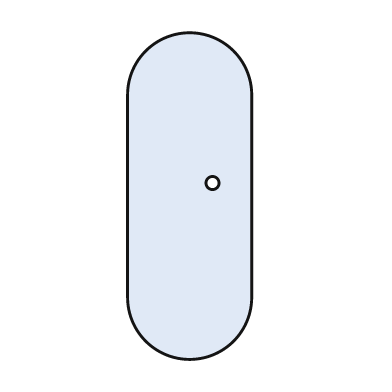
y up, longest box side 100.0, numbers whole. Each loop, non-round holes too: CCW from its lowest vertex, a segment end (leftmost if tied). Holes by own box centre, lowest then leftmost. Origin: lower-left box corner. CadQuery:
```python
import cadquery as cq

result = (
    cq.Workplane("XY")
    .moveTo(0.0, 19.0)
    .threePointArc((19.0, 0.0), (38.0, 19.0))
    .lineTo(38.0, 81.0)
    .threePointArc((19.0, 100.0), (0.0, 81.0))
    .close()
    .moveTo(26.0, 54.0)
    .circle(2.0)
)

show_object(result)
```